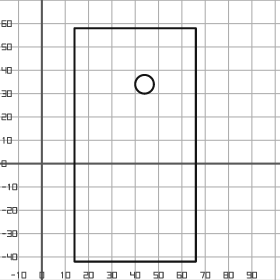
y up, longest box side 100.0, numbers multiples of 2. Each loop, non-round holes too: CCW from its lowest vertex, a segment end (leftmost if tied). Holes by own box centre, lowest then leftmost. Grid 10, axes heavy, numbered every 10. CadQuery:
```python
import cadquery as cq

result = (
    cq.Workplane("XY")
    .moveTo(14.0, -42.0)
    .lineTo(66.0, -42.0)
    .lineTo(66.0, 58.0)
    .lineTo(14.0, 58.0)
    .close()
    .moveTo(44.0, 34.0)
    .circle(4.0)
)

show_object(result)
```